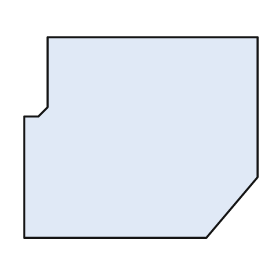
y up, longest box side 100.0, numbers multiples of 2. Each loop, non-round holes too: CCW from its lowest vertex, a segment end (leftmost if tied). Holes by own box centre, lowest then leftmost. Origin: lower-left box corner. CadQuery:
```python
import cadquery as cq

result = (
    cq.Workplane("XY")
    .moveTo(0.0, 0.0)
    .lineTo(78.0, 0.0)
    .lineTo(100.0, 26.0)
    .lineTo(100.0, 86.0)
    .lineTo(10.0, 86.0)
    .lineTo(10.0, 56.0)
    .lineTo(6.0, 52.0)
    .lineTo(0.0, 52.0)
    .close()
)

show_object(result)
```